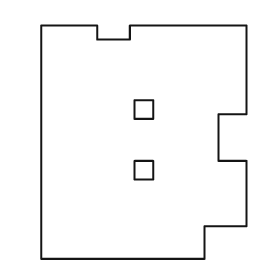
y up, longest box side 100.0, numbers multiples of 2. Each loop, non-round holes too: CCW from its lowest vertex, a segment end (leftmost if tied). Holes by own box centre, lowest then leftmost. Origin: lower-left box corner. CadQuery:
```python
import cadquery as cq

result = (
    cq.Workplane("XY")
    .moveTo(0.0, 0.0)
    .lineTo(70.0, 0.0)
    .lineTo(70.0, 14.0)
    .lineTo(88.0, 14.0)
    .lineTo(88.0, 42.0)
    .lineTo(76.0, 42.0)
    .lineTo(76.0, 62.0)
    .lineTo(88.0, 62.0)
    .lineTo(88.0, 100.0)
    .lineTo(38.0, 100.0)
    .lineTo(38.0, 94.0)
    .lineTo(24.0, 94.0)
    .lineTo(24.0, 100.0)
    .lineTo(0.0, 100.0)
    .close()
    .moveTo(40.0, 34.0)
    .lineTo(48.0, 34.0)
    .lineTo(48.0, 42.0)
    .lineTo(40.0, 42.0)
    .close()
    .moveTo(40.0, 60.0)
    .lineTo(48.0, 60.0)
    .lineTo(48.0, 68.0)
    .lineTo(40.0, 68.0)
    .close()
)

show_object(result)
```